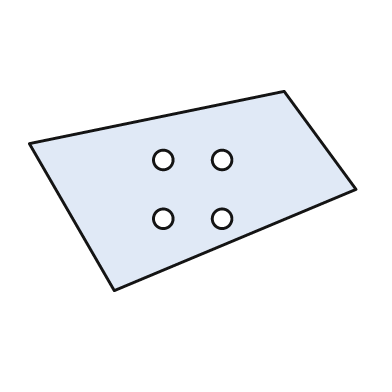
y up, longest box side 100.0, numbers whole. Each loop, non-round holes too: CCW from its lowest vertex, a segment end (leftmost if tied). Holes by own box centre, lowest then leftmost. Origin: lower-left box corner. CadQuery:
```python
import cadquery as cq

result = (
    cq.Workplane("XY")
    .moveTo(26.0, 0.0)
    .lineTo(100.0, 31.0)
    .lineTo(78.0, 61.0)
    .lineTo(0.0, 45.0)
    .close()
    .moveTo(41.0, 22.0)
    .circle(3.0)
    .moveTo(59.0, 22.0)
    .circle(3.0)
    .moveTo(41.0, 40.0)
    .circle(3.0)
    .moveTo(59.0, 40.0)
    .circle(3.0)
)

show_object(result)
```